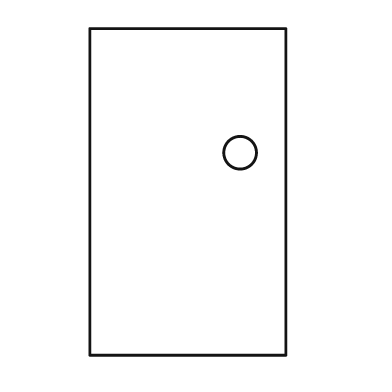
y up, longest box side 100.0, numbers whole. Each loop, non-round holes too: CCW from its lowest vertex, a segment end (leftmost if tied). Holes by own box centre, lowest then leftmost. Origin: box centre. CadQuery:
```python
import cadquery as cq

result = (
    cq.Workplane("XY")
    .moveTo(-30.0, -50.0)
    .lineTo(30.0, -50.0)
    .lineTo(30.0, 50.0)
    .lineTo(-30.0, 50.0)
    .close()
    .moveTo(16.0, 12.0)
    .circle(5.0)
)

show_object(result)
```